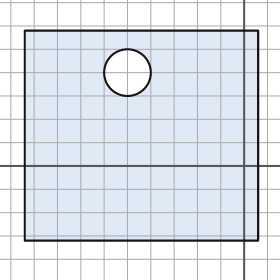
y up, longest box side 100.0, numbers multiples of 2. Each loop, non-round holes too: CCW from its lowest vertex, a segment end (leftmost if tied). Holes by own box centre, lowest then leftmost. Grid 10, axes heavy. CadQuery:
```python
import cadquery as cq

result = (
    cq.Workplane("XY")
    .moveTo(-94.0, -32.0)
    .lineTo(6.0, -32.0)
    .lineTo(6.0, 58.0)
    .lineTo(-94.0, 58.0)
    .close()
    .moveTo(-50.0, 40.0)
    .circle(10.0)
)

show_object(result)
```